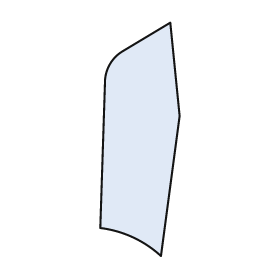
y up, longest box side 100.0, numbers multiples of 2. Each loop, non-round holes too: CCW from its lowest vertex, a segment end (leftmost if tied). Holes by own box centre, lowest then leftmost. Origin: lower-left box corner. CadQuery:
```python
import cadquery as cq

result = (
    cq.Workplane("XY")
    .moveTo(26.0, 0.0)
    .lineTo(34.0, 60.0)
    .lineTo(30.0, 100.0)
    .lineTo(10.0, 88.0)
    .threePointArc((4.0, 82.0), (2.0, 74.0))
    .lineTo(0.0, 12.0)
    .threePointArc((14.0, 8.0), (26.0, 0.0))
    .close()
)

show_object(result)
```